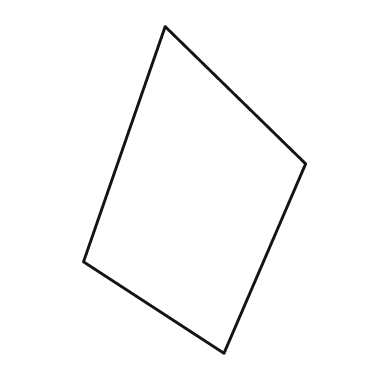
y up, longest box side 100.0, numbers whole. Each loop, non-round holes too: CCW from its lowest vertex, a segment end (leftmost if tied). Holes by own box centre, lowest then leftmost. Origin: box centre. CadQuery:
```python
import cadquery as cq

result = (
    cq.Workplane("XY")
    .moveTo(9.0, -50.0)
    .lineTo(34.0, 8.0)
    .lineTo(-9.0, 50.0)
    .lineTo(-34.0, -22.0)
    .close()
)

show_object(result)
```